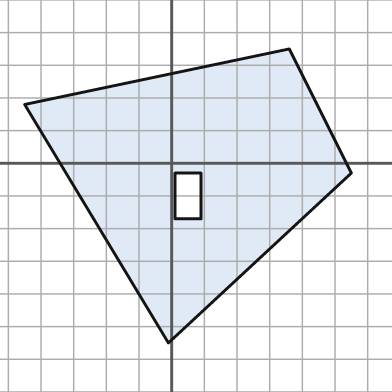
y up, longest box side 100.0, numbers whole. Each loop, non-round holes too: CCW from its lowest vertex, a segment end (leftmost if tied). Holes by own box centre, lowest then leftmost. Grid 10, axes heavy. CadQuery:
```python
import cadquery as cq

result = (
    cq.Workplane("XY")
    .moveTo(-1.0, -55.0)
    .lineTo(55.0, -3.0)
    .lineTo(36.0, 35.0)
    .lineTo(-45.0, 18.0)
    .close()
    .moveTo(1.0, -17.0)
    .lineTo(9.0, -17.0)
    .lineTo(9.0, -3.0)
    .lineTo(1.0, -3.0)
    .close()
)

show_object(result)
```